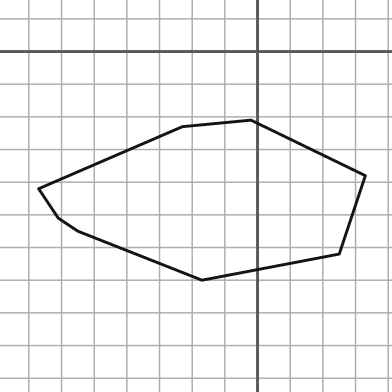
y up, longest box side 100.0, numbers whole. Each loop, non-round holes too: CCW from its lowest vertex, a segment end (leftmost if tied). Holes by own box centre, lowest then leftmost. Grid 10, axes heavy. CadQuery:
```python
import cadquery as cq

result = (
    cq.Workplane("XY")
    .moveTo(-17.0, -70.0)
    .lineTo(25.0, -62.0)
    .lineTo(33.0, -38.0)
    .lineTo(-2.0, -21.0)
    .lineTo(-23.0, -23.0)
    .lineTo(-67.0, -42.0)
    .lineTo(-61.0, -51.0)
    .lineTo(-55.0, -55.0)
    .close()
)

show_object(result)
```